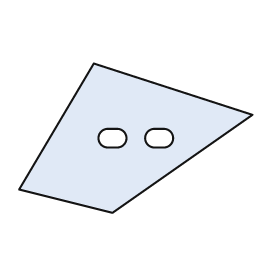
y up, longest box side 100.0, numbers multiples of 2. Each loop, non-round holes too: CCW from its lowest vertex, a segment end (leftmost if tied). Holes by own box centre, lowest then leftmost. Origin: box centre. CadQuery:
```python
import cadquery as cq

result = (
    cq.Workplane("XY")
    .moveTo(-10.0, -32.0)
    .lineTo(50.0, 10.0)
    .lineTo(-18.0, 32.0)
    .lineTo(-50.0, -22.0)
    .close()
    .moveTo(-12.0, -4.0)
    .lineTo(-8.0, -4.0)
    .threePointArc((-4.0, 0.0), (-8.0, 4.0))
    .lineTo(-12.0, 4.0)
    .threePointArc((-16.0, 0.0), (-12.0, -4.0))
    .close()
    .moveTo(8.0, -4.0)
    .lineTo(12.0, -4.0)
    .threePointArc((16.0, 0.0), (12.0, 4.0))
    .lineTo(8.0, 4.0)
    .threePointArc((4.0, 0.0), (8.0, -4.0))
    .close()
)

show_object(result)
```